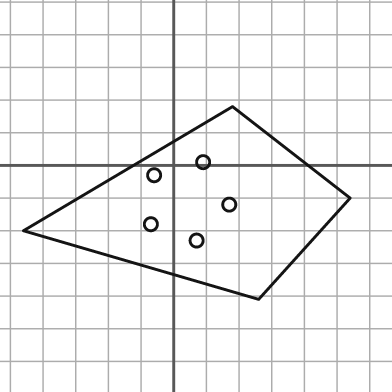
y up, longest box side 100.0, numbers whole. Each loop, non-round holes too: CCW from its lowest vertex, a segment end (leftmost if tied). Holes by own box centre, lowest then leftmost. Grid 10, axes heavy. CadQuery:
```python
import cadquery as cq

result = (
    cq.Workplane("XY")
    .moveTo(26.0, -41.0)
    .lineTo(54.0, -10.0)
    .lineTo(18.0, 18.0)
    .lineTo(-46.0, -20.0)
    .close()
    .moveTo(7.0, -23.0)
    .circle(2.0)
    .moveTo(-7.0, -18.0)
    .circle(2.0)
    .moveTo(17.0, -12.0)
    .circle(2.0)
    .moveTo(-6.0, -3.0)
    .circle(2.0)
    .moveTo(9.0, 1.0)
    .circle(2.0)
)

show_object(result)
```